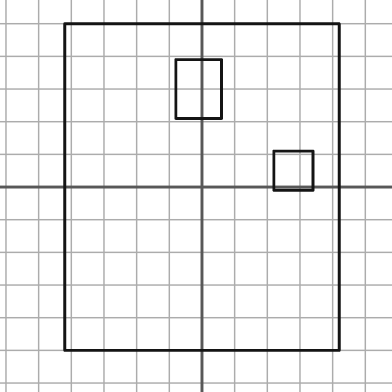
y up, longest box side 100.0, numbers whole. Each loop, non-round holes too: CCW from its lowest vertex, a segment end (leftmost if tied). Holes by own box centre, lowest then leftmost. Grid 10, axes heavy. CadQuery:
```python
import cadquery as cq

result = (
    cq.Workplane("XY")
    .moveTo(-42.0, -50.0)
    .lineTo(42.0, -50.0)
    .lineTo(42.0, 50.0)
    .lineTo(-42.0, 50.0)
    .close()
    .moveTo(22.0, -1.0)
    .lineTo(34.0, -1.0)
    .lineTo(34.0, 11.0)
    .lineTo(22.0, 11.0)
    .close()
    .moveTo(-8.0, 21.0)
    .lineTo(6.0, 21.0)
    .lineTo(6.0, 39.0)
    .lineTo(-8.0, 39.0)
    .close()
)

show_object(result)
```